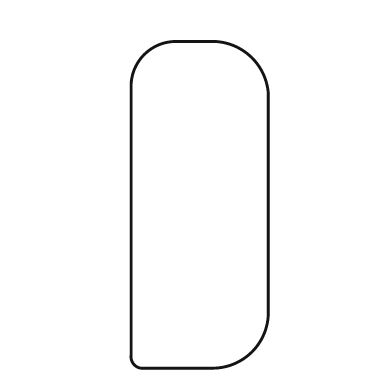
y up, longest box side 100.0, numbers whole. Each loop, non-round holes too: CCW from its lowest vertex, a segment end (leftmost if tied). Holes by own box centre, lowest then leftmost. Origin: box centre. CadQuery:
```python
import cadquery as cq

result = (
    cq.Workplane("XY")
    .moveTo(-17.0, -50.0)
    .lineTo(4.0, -50.0)
    .threePointArc((16.0, -45.0), (21.0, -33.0))
    .lineTo(21.0, 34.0)
    .threePointArc((16.0, 45.0), (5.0, 50.0))
    .lineTo(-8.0, 50.0)
    .threePointArc((-17.0, 46.0), (-21.0, 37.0))
    .lineTo(-21.0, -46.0)
    .threePointArc((-20.0, -49.0), (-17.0, -50.0))
    .close()
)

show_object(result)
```